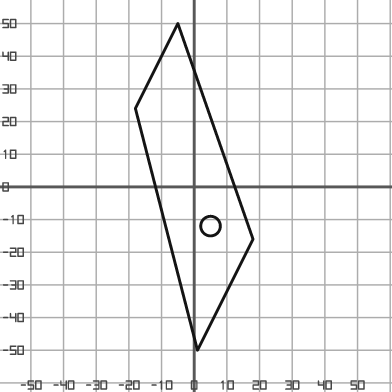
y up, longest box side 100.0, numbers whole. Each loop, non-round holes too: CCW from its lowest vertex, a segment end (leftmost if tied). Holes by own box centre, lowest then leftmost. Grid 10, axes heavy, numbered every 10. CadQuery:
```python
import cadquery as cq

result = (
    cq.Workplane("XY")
    .moveTo(1.0, -50.0)
    .lineTo(18.0, -16.0)
    .lineTo(-5.0, 50.0)
    .lineTo(-18.0, 24.0)
    .close()
    .moveTo(5.0, -12.0)
    .circle(3.0)
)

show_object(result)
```